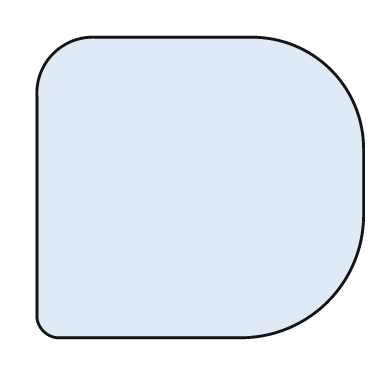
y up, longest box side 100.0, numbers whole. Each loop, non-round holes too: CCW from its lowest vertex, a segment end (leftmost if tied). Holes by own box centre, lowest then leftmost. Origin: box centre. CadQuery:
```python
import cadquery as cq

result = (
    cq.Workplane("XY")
    .moveTo(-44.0, -46.0)
    .lineTo(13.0, -46.0)
    .threePointArc((39.0, -35.0), (50.0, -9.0))
    .lineTo(50.0, 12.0)
    .threePointArc((40.0, 36.0), (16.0, 46.0))
    .lineTo(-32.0, 46.0)
    .threePointArc((-45.0, 41.0), (-50.0, 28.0))
    .lineTo(-50.0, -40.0)
    .threePointArc((-48.0, -44.0), (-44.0, -46.0))
    .close()
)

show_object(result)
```